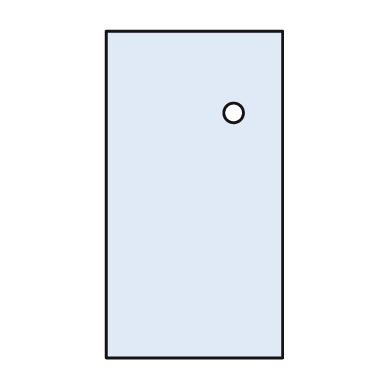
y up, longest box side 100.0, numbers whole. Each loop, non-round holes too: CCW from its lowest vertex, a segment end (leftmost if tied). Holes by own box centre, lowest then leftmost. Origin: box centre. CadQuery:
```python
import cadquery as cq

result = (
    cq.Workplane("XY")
    .moveTo(-27.0, -50.0)
    .lineTo(27.0, -50.0)
    .lineTo(27.0, 50.0)
    .lineTo(-27.0, 50.0)
    .close()
    .moveTo(12.0, 25.0)
    .circle(3.0)
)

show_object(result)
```